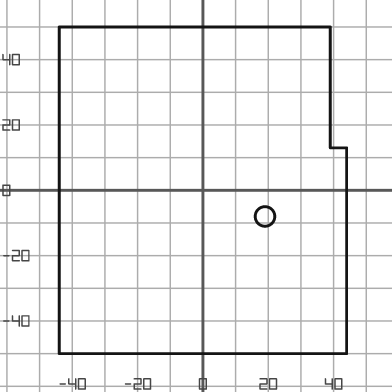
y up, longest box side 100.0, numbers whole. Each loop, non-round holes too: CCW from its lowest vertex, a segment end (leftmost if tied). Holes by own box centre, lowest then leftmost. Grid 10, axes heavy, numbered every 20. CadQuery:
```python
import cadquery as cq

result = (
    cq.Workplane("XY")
    .moveTo(-44.0, -50.0)
    .lineTo(44.0, -50.0)
    .lineTo(44.0, 13.0)
    .lineTo(39.0, 13.0)
    .lineTo(39.0, 50.0)
    .lineTo(-44.0, 50.0)
    .close()
    .moveTo(19.0, -8.0)
    .circle(3.0)
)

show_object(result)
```